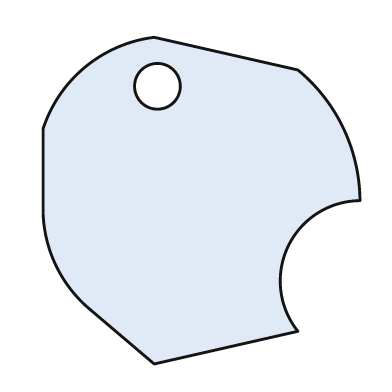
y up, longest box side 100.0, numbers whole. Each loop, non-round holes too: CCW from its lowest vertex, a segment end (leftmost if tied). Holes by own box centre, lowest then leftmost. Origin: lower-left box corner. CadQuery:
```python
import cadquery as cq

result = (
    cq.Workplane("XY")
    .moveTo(34.0, 0.0)
    .lineTo(78.0, 10.0)
    .threePointArc((75.0, 36.0), (97.0, 50.0))
    .threePointArc((92.0, 72.0), (78.0, 90.0))
    .lineTo(34.0, 100.0)
    .threePointArc((13.0, 91.0), (0.0, 72.0))
    .lineTo(0.0, 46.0)
    .threePointArc((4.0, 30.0), (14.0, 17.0))
    .close()
    .moveTo(35.0, 85.0)
    .circle(7.0)
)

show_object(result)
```